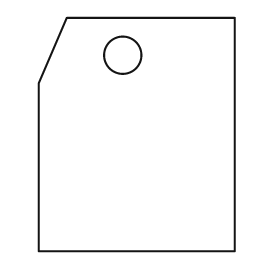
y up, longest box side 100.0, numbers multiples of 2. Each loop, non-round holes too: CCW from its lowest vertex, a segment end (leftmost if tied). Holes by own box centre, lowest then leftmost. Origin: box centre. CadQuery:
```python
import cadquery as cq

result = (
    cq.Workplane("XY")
    .moveTo(-42.0, -50.0)
    .lineTo(42.0, -50.0)
    .lineTo(42.0, 50.0)
    .lineTo(-30.0, 50.0)
    .lineTo(-42.0, 22.0)
    .close()
    .moveTo(-6.0, 34.0)
    .circle(8.0)
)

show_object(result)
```